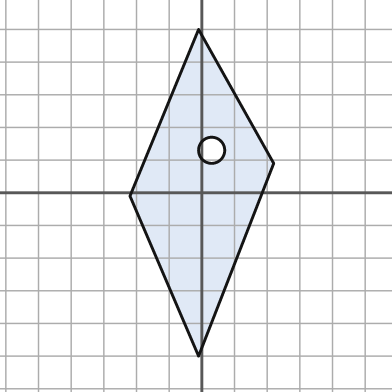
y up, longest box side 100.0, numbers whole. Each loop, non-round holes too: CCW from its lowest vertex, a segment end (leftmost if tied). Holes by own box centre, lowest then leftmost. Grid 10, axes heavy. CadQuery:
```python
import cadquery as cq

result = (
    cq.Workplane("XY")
    .moveTo(-1.0, -50.0)
    .lineTo(22.0, 9.0)
    .lineTo(-1.0, 50.0)
    .lineTo(-22.0, -1.0)
    .close()
    .moveTo(3.0, 13.0)
    .circle(4.0)
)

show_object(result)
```